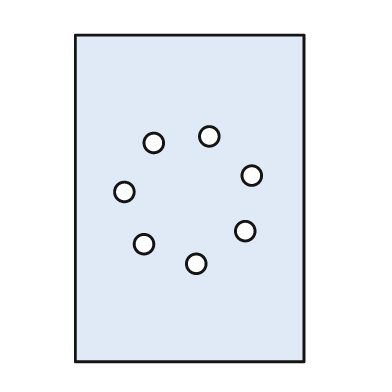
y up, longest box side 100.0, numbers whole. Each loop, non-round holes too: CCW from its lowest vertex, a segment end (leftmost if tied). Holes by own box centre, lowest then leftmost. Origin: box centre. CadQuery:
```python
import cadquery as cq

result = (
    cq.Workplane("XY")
    .moveTo(-35.0, -50.0)
    .lineTo(35.0, -50.0)
    .lineTo(35.0, 50.0)
    .lineTo(-35.0, 50.0)
    .close()
    .moveTo(2.0, -20.0)
    .circle(3.0)
    .moveTo(-14.0, -14.0)
    .circle(3.0)
    .moveTo(17.0, -10.0)
    .circle(3.0)
    .moveTo(-20.0, 2.0)
    .circle(3.0)
    .moveTo(19.0, 7.0)
    .circle(3.0)
    .moveTo(-11.0, 17.0)
    .circle(3.0)
    .moveTo(6.0, 19.0)
    .circle(3.0)
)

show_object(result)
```